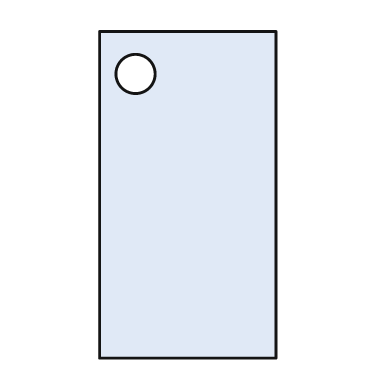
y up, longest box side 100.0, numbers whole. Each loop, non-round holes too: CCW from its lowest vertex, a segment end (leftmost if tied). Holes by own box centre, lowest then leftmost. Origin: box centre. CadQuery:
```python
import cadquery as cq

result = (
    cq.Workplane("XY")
    .moveTo(-27.0, -50.0)
    .lineTo(27.0, -50.0)
    .lineTo(27.0, 50.0)
    .lineTo(-27.0, 50.0)
    .close()
    .moveTo(-16.0, 37.0)
    .circle(6.0)
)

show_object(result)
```